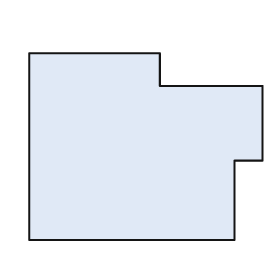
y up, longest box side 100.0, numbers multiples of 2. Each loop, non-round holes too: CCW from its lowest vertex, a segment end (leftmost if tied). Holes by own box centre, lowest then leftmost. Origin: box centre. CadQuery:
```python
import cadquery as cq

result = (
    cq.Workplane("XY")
    .moveTo(-50.0, -40.0)
    .lineTo(38.0, -40.0)
    .lineTo(38.0, -6.0)
    .lineTo(50.0, -6.0)
    .lineTo(50.0, 26.0)
    .lineTo(6.0, 26.0)
    .lineTo(6.0, 40.0)
    .lineTo(-50.0, 40.0)
    .close()
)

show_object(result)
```